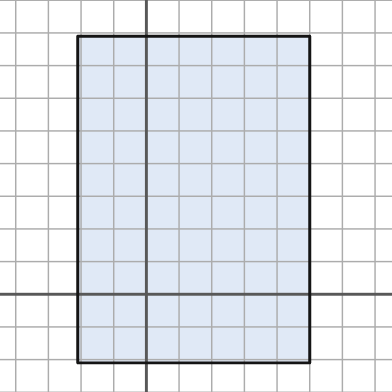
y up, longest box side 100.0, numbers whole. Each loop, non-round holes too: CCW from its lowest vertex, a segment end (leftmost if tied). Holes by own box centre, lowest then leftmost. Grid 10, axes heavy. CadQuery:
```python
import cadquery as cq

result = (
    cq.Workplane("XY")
    .moveTo(-21.0, -21.0)
    .lineTo(50.0, -21.0)
    .lineTo(50.0, 79.0)
    .lineTo(-21.0, 79.0)
    .close()
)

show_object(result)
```